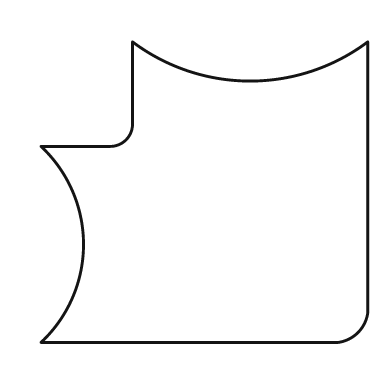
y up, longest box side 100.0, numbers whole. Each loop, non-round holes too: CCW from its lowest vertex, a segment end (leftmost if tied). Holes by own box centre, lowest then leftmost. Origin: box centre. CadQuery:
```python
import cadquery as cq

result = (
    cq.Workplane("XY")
    .moveTo(-50.0, -46.0)
    .lineTo(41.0, -46.0)
    .threePointArc((47.0, -43.0), (50.0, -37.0))
    .lineTo(50.0, 46.0)
    .threePointArc((14.0, 34.0), (-22.0, 46.0))
    .lineTo(-22.0, 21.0)
    .threePointArc((-24.0, 16.0), (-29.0, 14.0))
    .lineTo(-50.0, 14.0)
    .threePointArc((-37.0, -16.0), (-50.0, -46.0))
    .close()
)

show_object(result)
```